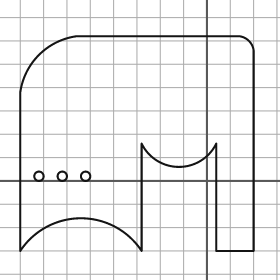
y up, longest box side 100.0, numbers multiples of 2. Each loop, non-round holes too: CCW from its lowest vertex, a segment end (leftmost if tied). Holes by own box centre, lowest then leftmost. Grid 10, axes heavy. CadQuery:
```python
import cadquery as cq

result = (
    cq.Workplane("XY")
    .moveTo(-80.0, -30.0)
    .threePointArc((-54.0, -16.0), (-28.0, -30.0))
    .lineTo(-28.0, 16.0)
    .threePointArc((-12.0, 6.0), (4.0, 16.0))
    .lineTo(4.0, -30.0)
    .lineTo(20.0, -30.0)
    .lineTo(20.0, 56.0)
    .threePointArc((18.0, 60.0), (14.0, 62.0))
    .lineTo(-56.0, 62.0)
    .threePointArc((-72.0, 54.0), (-80.0, 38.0))
    .close()
    .moveTo(-72.0, 2.0)
    .circle(2.0)
    .moveTo(-62.0, 2.0)
    .circle(2.0)
    .moveTo(-52.0, 2.0)
    .circle(2.0)
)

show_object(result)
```